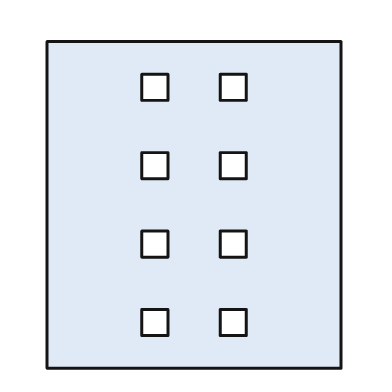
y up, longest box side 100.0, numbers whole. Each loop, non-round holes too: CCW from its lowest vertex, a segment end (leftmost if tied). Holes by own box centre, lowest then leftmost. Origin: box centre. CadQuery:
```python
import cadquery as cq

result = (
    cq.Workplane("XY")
    .moveTo(-45.0, -50.0)
    .lineTo(45.0, -50.0)
    .lineTo(45.0, 50.0)
    .lineTo(-45.0, 50.0)
    .close()
    .moveTo(-16.0, -40.0)
    .lineTo(-8.0, -40.0)
    .lineTo(-8.0, -32.0)
    .lineTo(-16.0, -32.0)
    .close()
    .moveTo(8.0, -40.0)
    .lineTo(16.0, -40.0)
    .lineTo(16.0, -32.0)
    .lineTo(8.0, -32.0)
    .close()
    .moveTo(-16.0, -16.0)
    .lineTo(-8.0, -16.0)
    .lineTo(-8.0, -8.0)
    .lineTo(-16.0, -8.0)
    .close()
    .moveTo(8.0, -16.0)
    .lineTo(16.0, -16.0)
    .lineTo(16.0, -8.0)
    .lineTo(8.0, -8.0)
    .close()
    .moveTo(-16.0, 8.0)
    .lineTo(-8.0, 8.0)
    .lineTo(-8.0, 16.0)
    .lineTo(-16.0, 16.0)
    .close()
    .moveTo(8.0, 8.0)
    .lineTo(16.0, 8.0)
    .lineTo(16.0, 16.0)
    .lineTo(8.0, 16.0)
    .close()
    .moveTo(-16.0, 32.0)
    .lineTo(-8.0, 32.0)
    .lineTo(-8.0, 40.0)
    .lineTo(-16.0, 40.0)
    .close()
    .moveTo(8.0, 32.0)
    .lineTo(16.0, 32.0)
    .lineTo(16.0, 40.0)
    .lineTo(8.0, 40.0)
    .close()
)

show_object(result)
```